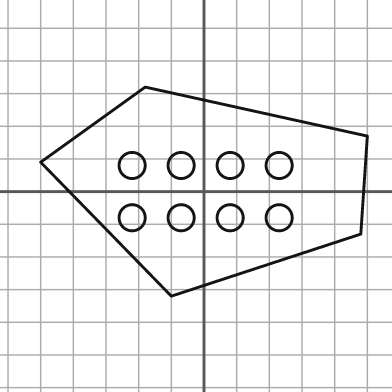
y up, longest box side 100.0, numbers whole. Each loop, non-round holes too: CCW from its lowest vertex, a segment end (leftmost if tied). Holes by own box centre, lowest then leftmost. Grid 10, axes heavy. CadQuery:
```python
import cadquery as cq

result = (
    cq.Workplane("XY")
    .moveTo(-10.0, -32.0)
    .lineTo(48.0, -13.0)
    .lineTo(50.0, 17.0)
    .lineTo(-18.0, 32.0)
    .lineTo(-50.0, 9.0)
    .close()
    .moveTo(-22.0, -8.0)
    .circle(4.0)
    .moveTo(-7.0, -8.0)
    .circle(4.0)
    .moveTo(8.0, -8.0)
    .circle(4.0)
    .moveTo(23.0, -8.0)
    .circle(4.0)
    .moveTo(-22.0, 8.0)
    .circle(4.0)
    .moveTo(-7.0, 8.0)
    .circle(4.0)
    .moveTo(8.0, 8.0)
    .circle(4.0)
    .moveTo(23.0, 8.0)
    .circle(4.0)
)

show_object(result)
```